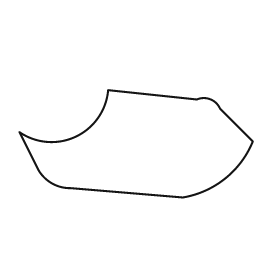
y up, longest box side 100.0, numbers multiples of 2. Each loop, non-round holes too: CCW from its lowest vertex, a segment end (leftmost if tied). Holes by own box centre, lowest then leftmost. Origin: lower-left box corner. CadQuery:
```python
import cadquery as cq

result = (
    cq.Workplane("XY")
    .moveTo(70.0, 0.0)
    .threePointArc((88.0, 8.0), (100.0, 24.0))
    .lineTo(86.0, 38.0)
    .threePointArc((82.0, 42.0), (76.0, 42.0))
    .lineTo(38.0, 46.0)
    .threePointArc((24.0, 26.0), (0.0, 28.0))
    .lineTo(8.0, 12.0)
    .threePointArc((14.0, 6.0), (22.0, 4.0))
    .close()
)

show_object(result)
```